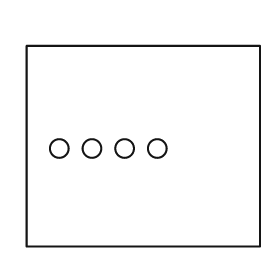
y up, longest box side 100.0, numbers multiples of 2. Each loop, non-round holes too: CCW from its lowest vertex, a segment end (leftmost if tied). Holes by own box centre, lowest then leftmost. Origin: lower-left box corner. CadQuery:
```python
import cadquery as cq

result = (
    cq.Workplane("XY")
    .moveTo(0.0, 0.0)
    .lineTo(100.0, 0.0)
    .lineTo(100.0, 86.0)
    .lineTo(0.0, 86.0)
    .close()
    .moveTo(14.0, 42.0)
    .circle(4.0)
    .moveTo(28.0, 42.0)
    .circle(4.0)
    .moveTo(42.0, 42.0)
    .circle(4.0)
    .moveTo(56.0, 42.0)
    .circle(4.0)
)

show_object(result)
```